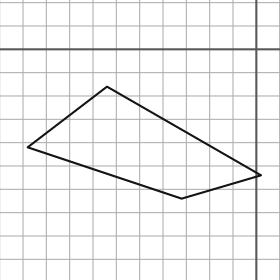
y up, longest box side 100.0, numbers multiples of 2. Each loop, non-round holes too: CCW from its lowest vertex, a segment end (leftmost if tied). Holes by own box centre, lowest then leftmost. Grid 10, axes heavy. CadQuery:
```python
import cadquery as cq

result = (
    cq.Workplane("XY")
    .moveTo(-32.0, -64.0)
    .lineTo(2.0, -54.0)
    .lineTo(-64.0, -16.0)
    .lineTo(-98.0, -42.0)
    .close()
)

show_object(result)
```